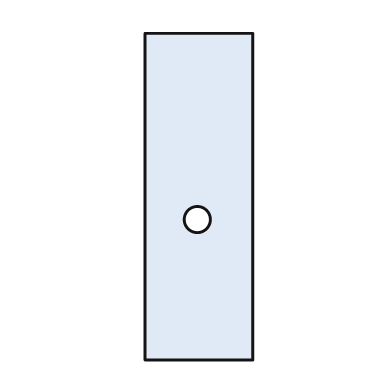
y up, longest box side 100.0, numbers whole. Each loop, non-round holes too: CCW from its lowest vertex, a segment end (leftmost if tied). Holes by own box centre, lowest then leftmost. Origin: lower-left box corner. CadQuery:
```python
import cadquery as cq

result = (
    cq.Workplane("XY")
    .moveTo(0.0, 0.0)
    .lineTo(33.0, 0.0)
    .lineTo(33.0, 100.0)
    .lineTo(0.0, 100.0)
    .close()
    .moveTo(16.0, 43.0)
    .circle(4.0)
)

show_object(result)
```